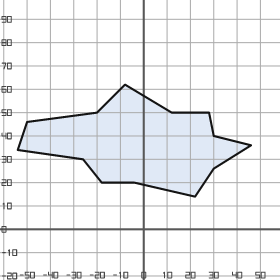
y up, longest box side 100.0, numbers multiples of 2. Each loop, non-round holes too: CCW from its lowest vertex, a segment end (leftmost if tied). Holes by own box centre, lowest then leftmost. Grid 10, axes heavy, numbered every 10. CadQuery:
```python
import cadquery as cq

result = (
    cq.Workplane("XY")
    .moveTo(22.0, 14.0)
    .lineTo(30.0, 26.0)
    .lineTo(46.0, 36.0)
    .lineTo(30.0, 40.0)
    .lineTo(28.0, 50.0)
    .lineTo(12.0, 50.0)
    .lineTo(-8.0, 62.0)
    .lineTo(-20.0, 50.0)
    .lineTo(-50.0, 46.0)
    .lineTo(-54.0, 34.0)
    .lineTo(-26.0, 30.0)
    .lineTo(-18.0, 20.0)
    .lineTo(-4.0, 20.0)
    .close()
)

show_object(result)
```